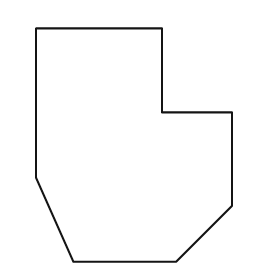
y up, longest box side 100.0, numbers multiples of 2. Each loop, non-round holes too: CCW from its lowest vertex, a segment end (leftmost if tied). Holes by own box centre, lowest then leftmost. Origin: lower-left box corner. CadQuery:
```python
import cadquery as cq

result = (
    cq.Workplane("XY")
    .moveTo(16.0, 0.0)
    .lineTo(60.0, 0.0)
    .lineTo(84.0, 24.0)
    .lineTo(84.0, 64.0)
    .lineTo(54.0, 64.0)
    .lineTo(54.0, 100.0)
    .lineTo(0.0, 100.0)
    .lineTo(0.0, 36.0)
    .close()
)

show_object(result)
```